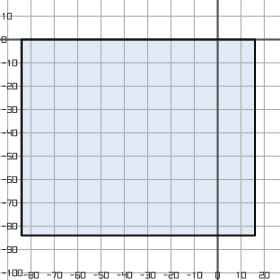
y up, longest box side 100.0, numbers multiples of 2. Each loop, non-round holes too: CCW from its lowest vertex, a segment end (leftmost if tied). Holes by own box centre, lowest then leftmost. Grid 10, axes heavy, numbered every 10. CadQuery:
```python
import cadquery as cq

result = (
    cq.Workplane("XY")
    .moveTo(-84.0, -84.0)
    .lineTo(16.0, -84.0)
    .lineTo(16.0, 0.0)
    .lineTo(-84.0, 0.0)
    .close()
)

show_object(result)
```